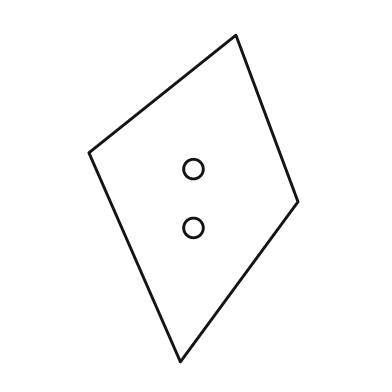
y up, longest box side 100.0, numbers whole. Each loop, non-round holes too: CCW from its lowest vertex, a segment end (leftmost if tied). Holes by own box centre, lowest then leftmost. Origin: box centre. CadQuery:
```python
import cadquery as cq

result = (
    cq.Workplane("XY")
    .moveTo(-4.0, -50.0)
    .lineTo(32.0, -1.0)
    .lineTo(13.0, 50.0)
    .lineTo(-32.0, 14.0)
    .close()
    .moveTo(0.0, -9.0)
    .circle(3.0)
    .moveTo(0.0, 9.0)
    .circle(3.0)
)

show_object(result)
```